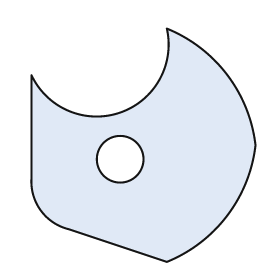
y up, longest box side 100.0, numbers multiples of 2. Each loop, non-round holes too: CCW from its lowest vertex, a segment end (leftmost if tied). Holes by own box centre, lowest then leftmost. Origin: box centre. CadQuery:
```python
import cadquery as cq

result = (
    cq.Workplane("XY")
    .moveTo(10.0, -50.0)
    .threePointArc((36.0, -30.0), (48.0, 0.0))
    .threePointArc((36.0, 30.0), (10.0, 50.0))
    .threePointArc((-10.0, 14.0), (-48.0, 30.0))
    .lineTo(-48.0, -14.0)
    .threePointArc((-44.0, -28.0), (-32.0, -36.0))
    .close()
    .moveTo(-10.0, -6.0)
    .circle(10.0)
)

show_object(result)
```